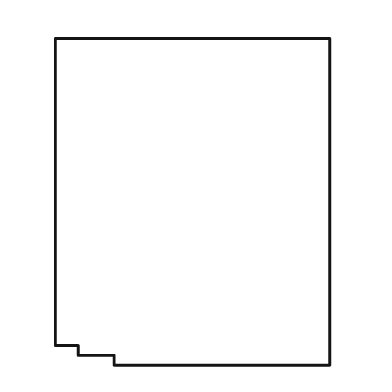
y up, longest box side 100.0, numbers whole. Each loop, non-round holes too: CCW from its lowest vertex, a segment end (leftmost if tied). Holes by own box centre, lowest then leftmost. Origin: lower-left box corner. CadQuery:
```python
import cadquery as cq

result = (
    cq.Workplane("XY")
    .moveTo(18.0, 0.0)
    .lineTo(84.0, 0.0)
    .lineTo(84.0, 100.0)
    .lineTo(0.0, 100.0)
    .lineTo(0.0, 6.0)
    .lineTo(7.0, 6.0)
    .lineTo(7.0, 3.0)
    .lineTo(18.0, 3.0)
    .close()
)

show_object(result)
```